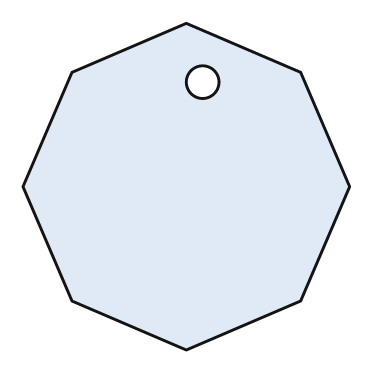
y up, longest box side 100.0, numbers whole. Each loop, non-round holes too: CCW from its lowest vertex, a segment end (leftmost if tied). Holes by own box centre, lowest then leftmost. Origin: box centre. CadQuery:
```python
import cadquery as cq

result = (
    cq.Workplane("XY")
    .moveTo(0.0, -50.0)
    .lineTo(35.0, -35.0)
    .lineTo(50.0, 0.0)
    .lineTo(35.0, 35.0)
    .lineTo(0.0, 50.0)
    .lineTo(-35.0, 35.0)
    .lineTo(-50.0, 0.0)
    .lineTo(-35.0, -35.0)
    .close()
    .moveTo(5.0, 32.0)
    .circle(5.0)
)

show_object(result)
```